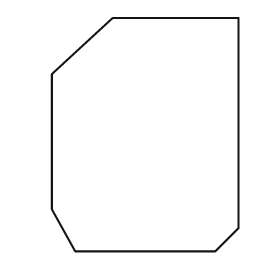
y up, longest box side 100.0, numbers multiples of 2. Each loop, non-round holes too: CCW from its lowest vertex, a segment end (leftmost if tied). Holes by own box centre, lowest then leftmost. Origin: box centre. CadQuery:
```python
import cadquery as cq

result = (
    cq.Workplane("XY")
    .moveTo(-30.0, -50.0)
    .lineTo(30.0, -50.0)
    .lineTo(40.0, -40.0)
    .lineTo(40.0, 50.0)
    .lineTo(-14.0, 50.0)
    .lineTo(-40.0, 26.0)
    .lineTo(-40.0, -32.0)
    .close()
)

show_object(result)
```